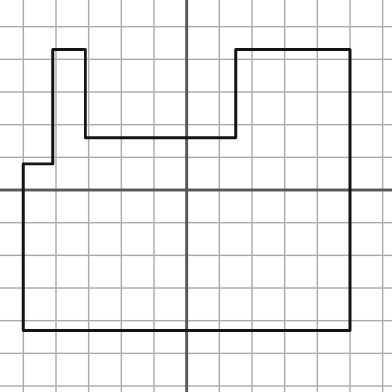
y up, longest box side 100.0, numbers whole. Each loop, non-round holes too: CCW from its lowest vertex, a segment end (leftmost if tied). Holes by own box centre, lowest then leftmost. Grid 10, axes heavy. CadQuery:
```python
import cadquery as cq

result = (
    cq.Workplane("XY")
    .moveTo(-50.0, -43.0)
    .lineTo(50.0, -43.0)
    .lineTo(50.0, 43.0)
    .lineTo(15.0, 43.0)
    .lineTo(15.0, 16.0)
    .lineTo(-31.0, 16.0)
    .lineTo(-31.0, 43.0)
    .lineTo(-41.0, 43.0)
    .lineTo(-41.0, 8.0)
    .lineTo(-50.0, 8.0)
    .close()
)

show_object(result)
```